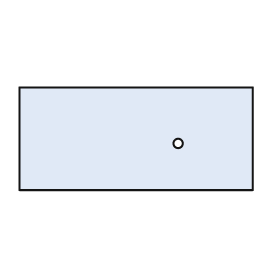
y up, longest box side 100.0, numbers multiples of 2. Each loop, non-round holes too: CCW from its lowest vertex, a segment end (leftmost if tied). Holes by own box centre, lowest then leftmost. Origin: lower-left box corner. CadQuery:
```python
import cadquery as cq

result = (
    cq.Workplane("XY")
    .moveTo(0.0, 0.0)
    .lineTo(100.0, 0.0)
    .lineTo(100.0, 44.0)
    .lineTo(0.0, 44.0)
    .close()
    .moveTo(68.0, 20.0)
    .circle(2.0)
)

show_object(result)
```